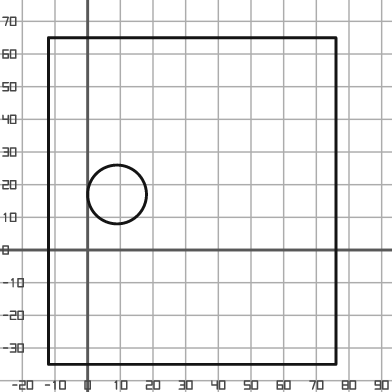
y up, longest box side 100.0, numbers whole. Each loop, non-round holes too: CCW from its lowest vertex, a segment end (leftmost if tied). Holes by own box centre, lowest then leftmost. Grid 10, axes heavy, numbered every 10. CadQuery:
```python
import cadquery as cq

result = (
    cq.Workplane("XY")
    .moveTo(-12.0, -35.0)
    .lineTo(76.0, -35.0)
    .lineTo(76.0, 65.0)
    .lineTo(-12.0, 65.0)
    .close()
    .moveTo(9.0, 17.0)
    .circle(9.0)
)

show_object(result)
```